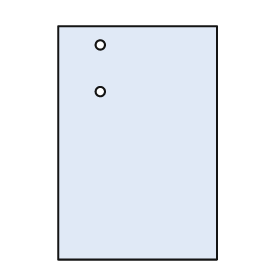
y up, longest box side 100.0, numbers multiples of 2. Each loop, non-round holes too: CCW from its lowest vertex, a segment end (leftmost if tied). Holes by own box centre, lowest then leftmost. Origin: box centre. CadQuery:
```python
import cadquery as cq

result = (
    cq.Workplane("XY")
    .moveTo(-34.0, -50.0)
    .lineTo(34.0, -50.0)
    .lineTo(34.0, 50.0)
    .lineTo(-34.0, 50.0)
    .close()
    .moveTo(-16.0, 22.0)
    .circle(2.0)
    .moveTo(-16.0, 42.0)
    .circle(2.0)
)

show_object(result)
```